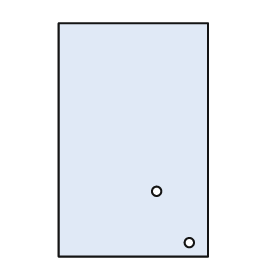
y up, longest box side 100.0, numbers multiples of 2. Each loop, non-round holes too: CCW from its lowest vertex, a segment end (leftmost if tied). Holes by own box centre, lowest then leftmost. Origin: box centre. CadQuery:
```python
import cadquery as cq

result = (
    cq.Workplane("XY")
    .moveTo(-32.0, -50.0)
    .lineTo(32.0, -50.0)
    .lineTo(32.0, 50.0)
    .lineTo(-32.0, 50.0)
    .close()
    .moveTo(24.0, -44.0)
    .circle(2.0)
    .moveTo(10.0, -22.0)
    .circle(2.0)
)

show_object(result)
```